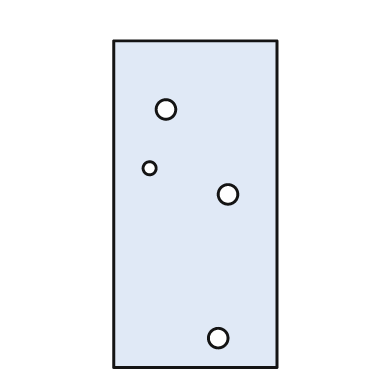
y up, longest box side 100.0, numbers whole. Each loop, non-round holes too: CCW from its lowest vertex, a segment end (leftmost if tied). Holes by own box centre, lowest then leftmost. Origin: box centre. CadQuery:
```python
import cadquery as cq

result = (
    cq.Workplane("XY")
    .moveTo(-25.0, -50.0)
    .lineTo(25.0, -50.0)
    .lineTo(25.0, 50.0)
    .lineTo(-25.0, 50.0)
    .close()
    .moveTo(7.0, -41.0)
    .circle(3.0)
    .moveTo(10.0, 3.0)
    .circle(3.0)
    .moveTo(-14.0, 11.0)
    .circle(2.0)
    .moveTo(-9.0, 29.0)
    .circle(3.0)
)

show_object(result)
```